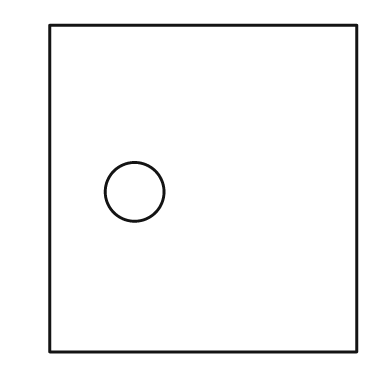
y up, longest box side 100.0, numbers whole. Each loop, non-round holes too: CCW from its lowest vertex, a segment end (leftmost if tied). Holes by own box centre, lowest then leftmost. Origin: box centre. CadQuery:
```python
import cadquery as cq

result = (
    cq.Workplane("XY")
    .moveTo(-47.0, -50.0)
    .lineTo(47.0, -50.0)
    .lineTo(47.0, 50.0)
    .lineTo(-47.0, 50.0)
    .close()
    .moveTo(-21.0, -1.0)
    .circle(9.0)
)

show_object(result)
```